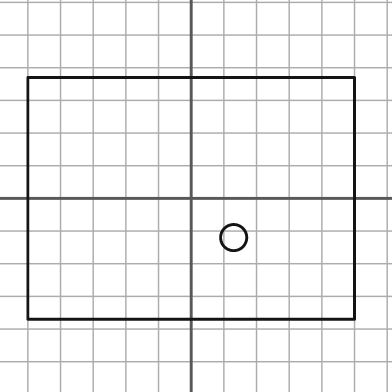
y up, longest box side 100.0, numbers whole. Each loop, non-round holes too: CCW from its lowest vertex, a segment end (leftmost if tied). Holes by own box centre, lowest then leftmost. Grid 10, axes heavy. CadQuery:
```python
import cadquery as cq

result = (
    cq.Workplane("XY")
    .moveTo(-50.0, -37.0)
    .lineTo(50.0, -37.0)
    .lineTo(50.0, 37.0)
    .lineTo(-50.0, 37.0)
    .close()
    .moveTo(13.0, -12.0)
    .circle(4.0)
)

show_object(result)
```